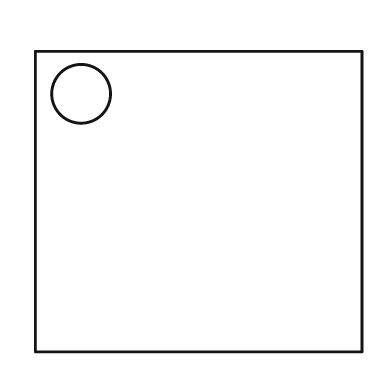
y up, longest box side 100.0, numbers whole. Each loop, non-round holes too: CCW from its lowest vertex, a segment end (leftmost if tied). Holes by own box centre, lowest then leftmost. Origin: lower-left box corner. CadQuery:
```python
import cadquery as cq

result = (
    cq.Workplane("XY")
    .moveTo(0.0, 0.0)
    .lineTo(100.0, 0.0)
    .lineTo(100.0, 92.0)
    .lineTo(0.0, 92.0)
    .close()
    .moveTo(14.0, 79.0)
    .circle(9.0)
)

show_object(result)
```